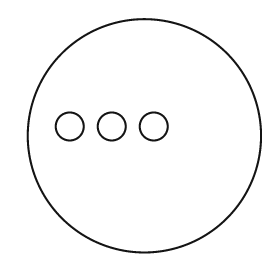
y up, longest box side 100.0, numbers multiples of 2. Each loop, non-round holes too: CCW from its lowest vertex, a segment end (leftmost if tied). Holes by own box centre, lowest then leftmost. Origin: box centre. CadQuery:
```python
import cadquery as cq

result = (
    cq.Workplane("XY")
    .moveTo(0.0, 0.0)
    .circle(50.0)
    .moveTo(-32.0, 4.0)
    .circle(6.0)
    .moveTo(-14.0, 4.0)
    .circle(6.0)
    .moveTo(4.0, 4.0)
    .circle(6.0)
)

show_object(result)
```